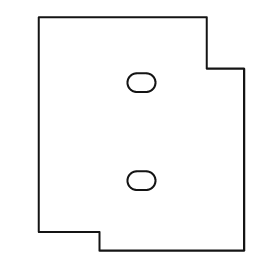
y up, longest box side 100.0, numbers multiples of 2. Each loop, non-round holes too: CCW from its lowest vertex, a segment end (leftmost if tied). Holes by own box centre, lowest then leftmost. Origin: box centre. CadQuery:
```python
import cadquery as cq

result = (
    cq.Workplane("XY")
    .moveTo(-18.0, -50.0)
    .lineTo(44.0, -50.0)
    .lineTo(44.0, 28.0)
    .lineTo(28.0, 28.0)
    .lineTo(28.0, 50.0)
    .lineTo(-44.0, 50.0)
    .lineTo(-44.0, -42.0)
    .lineTo(-18.0, -42.0)
    .close()
    .moveTo(-2.0, -24.0)
    .lineTo(2.0, -24.0)
    .threePointArc((6.0, -20.0), (2.0, -16.0))
    .lineTo(-2.0, -16.0)
    .threePointArc((-6.0, -20.0), (-2.0, -24.0))
    .close()
    .moveTo(-2.0, 18.0)
    .lineTo(2.0, 18.0)
    .threePointArc((6.0, 22.0), (2.0, 26.0))
    .lineTo(-2.0, 26.0)
    .threePointArc((-6.0, 22.0), (-2.0, 18.0))
    .close()
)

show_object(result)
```